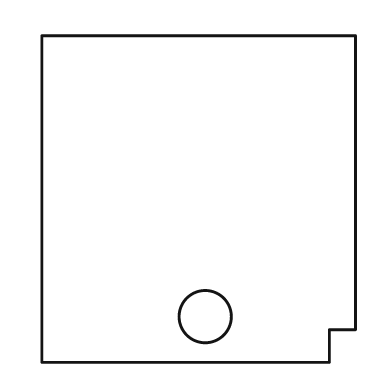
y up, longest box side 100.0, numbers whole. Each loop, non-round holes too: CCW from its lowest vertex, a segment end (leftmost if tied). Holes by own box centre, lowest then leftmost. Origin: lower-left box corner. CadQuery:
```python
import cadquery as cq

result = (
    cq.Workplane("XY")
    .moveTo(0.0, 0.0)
    .lineTo(88.0, 0.0)
    .lineTo(88.0, 10.0)
    .lineTo(96.0, 10.0)
    .lineTo(96.0, 100.0)
    .lineTo(0.0, 100.0)
    .close()
    .moveTo(50.0, 14.0)
    .circle(8.0)
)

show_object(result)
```